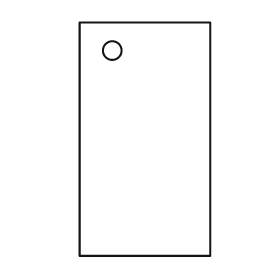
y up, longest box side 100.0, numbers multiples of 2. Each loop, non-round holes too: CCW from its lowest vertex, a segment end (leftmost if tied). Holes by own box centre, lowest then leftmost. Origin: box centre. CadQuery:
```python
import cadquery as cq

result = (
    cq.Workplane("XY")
    .moveTo(-28.0, -50.0)
    .lineTo(28.0, -50.0)
    .lineTo(28.0, 50.0)
    .lineTo(-28.0, 50.0)
    .close()
    .moveTo(-14.0, 38.0)
    .circle(4.0)
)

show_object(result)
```